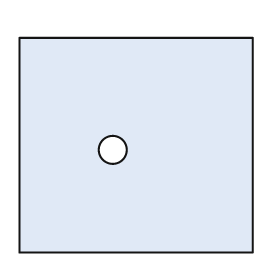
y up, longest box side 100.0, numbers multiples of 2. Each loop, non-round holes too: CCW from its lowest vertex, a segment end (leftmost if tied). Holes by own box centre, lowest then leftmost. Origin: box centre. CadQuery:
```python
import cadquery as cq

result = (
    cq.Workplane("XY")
    .moveTo(-50.0, -46.0)
    .lineTo(50.0, -46.0)
    .lineTo(50.0, 46.0)
    .lineTo(-50.0, 46.0)
    .close()
    .moveTo(-10.0, -2.0)
    .circle(6.0)
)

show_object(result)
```